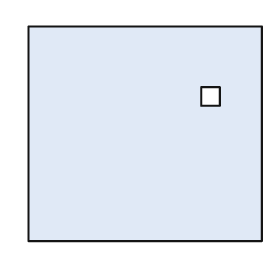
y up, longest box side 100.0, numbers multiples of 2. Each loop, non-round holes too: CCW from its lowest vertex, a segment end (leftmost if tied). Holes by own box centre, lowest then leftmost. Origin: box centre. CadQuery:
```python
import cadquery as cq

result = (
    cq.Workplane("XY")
    .moveTo(-50.0, -46.0)
    .lineTo(50.0, -46.0)
    .lineTo(50.0, 46.0)
    .lineTo(-50.0, 46.0)
    .close()
    .moveTo(24.0, 12.0)
    .lineTo(32.0, 12.0)
    .lineTo(32.0, 20.0)
    .lineTo(24.0, 20.0)
    .close()
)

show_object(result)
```